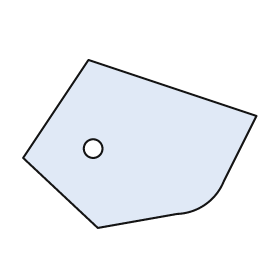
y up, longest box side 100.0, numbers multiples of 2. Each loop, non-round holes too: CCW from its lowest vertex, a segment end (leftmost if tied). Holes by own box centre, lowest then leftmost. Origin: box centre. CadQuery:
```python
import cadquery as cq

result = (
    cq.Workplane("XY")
    .moveTo(-18.0, -36.0)
    .lineTo(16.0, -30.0)
    .threePointArc((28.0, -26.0), (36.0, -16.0))
    .lineTo(50.0, 12.0)
    .lineTo(-22.0, 36.0)
    .lineTo(-50.0, -6.0)
    .close()
    .moveTo(-20.0, -2.0)
    .circle(4.0)
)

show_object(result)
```